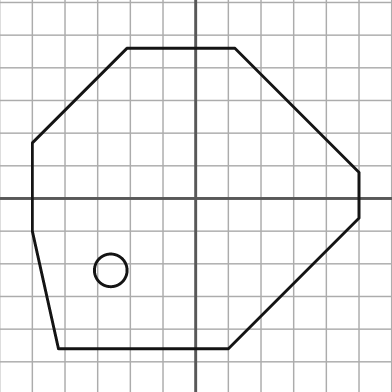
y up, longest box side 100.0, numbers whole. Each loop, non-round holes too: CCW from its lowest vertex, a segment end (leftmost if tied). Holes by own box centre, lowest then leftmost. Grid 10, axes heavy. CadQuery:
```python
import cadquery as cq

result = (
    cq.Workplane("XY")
    .moveTo(-42.0, -46.0)
    .lineTo(10.0, -46.0)
    .lineTo(50.0, -6.0)
    .lineTo(50.0, 8.0)
    .lineTo(12.0, 46.0)
    .lineTo(-21.0, 46.0)
    .lineTo(-50.0, 17.0)
    .lineTo(-50.0, -10.0)
    .close()
    .moveTo(-26.0, -22.0)
    .circle(5.0)
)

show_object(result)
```